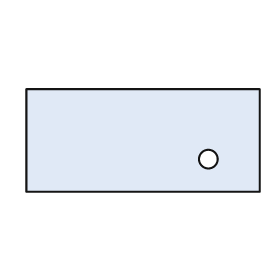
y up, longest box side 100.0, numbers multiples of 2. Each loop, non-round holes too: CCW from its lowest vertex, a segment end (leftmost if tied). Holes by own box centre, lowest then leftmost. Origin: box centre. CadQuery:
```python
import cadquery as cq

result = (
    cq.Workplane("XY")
    .moveTo(-50.0, -22.0)
    .lineTo(50.0, -22.0)
    .lineTo(50.0, 22.0)
    .lineTo(-50.0, 22.0)
    .close()
    .moveTo(28.0, -8.0)
    .circle(4.0)
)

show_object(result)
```